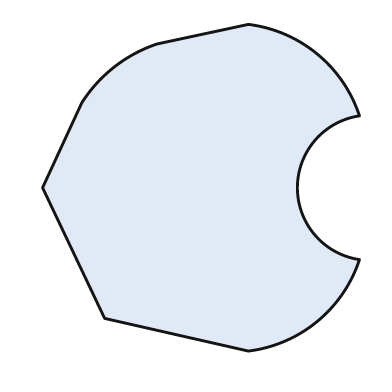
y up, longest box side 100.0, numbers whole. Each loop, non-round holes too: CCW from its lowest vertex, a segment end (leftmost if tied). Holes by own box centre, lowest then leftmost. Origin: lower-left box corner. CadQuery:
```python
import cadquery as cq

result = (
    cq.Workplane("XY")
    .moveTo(63.0, 0.0)
    .threePointArc((84.0, 9.0), (97.0, 28.0))
    .threePointArc((78.0, 50.0), (97.0, 72.0))
    .threePointArc((84.0, 91.0), (63.0, 100.0))
    .lineTo(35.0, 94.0)
    .threePointArc((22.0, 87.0), (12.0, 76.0))
    .lineTo(0.0, 50.0)
    .lineTo(19.0, 10.0)
    .close()
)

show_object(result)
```